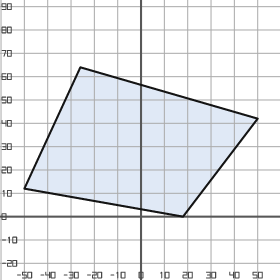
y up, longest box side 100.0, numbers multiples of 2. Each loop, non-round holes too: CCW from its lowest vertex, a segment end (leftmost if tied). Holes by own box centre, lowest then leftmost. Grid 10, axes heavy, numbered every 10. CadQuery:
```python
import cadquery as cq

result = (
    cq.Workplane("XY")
    .moveTo(18.0, 0.0)
    .lineTo(50.0, 42.0)
    .lineTo(-26.0, 64.0)
    .lineTo(-50.0, 12.0)
    .close()
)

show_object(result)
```